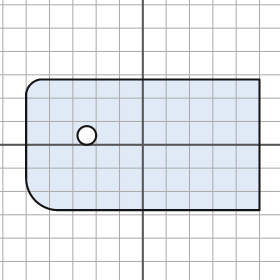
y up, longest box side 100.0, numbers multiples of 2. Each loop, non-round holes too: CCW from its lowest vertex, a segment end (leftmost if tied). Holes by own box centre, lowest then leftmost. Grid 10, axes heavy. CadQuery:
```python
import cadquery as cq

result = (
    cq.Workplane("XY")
    .moveTo(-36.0, -28.0)
    .lineTo(50.0, -28.0)
    .lineTo(50.0, 28.0)
    .lineTo(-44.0, 28.0)
    .threePointArc((-48.0, 26.0), (-50.0, 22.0))
    .lineTo(-50.0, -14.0)
    .threePointArc((-46.0, -24.0), (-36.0, -28.0))
    .close()
    .moveTo(-24.0, 4.0)
    .circle(4.0)
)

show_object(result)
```